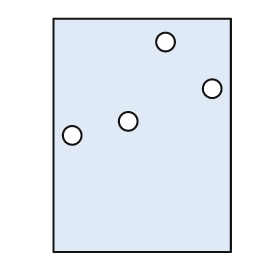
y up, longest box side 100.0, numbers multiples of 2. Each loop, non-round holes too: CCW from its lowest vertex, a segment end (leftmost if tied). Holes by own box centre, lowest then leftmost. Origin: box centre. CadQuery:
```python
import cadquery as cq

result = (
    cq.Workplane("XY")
    .moveTo(-38.0, -50.0)
    .lineTo(38.0, -50.0)
    .lineTo(38.0, 50.0)
    .lineTo(-38.0, 50.0)
    .close()
    .moveTo(-30.0, 0.0)
    .circle(4.0)
    .moveTo(-6.0, 6.0)
    .circle(4.0)
    .moveTo(30.0, 20.0)
    .circle(4.0)
    .moveTo(10.0, 40.0)
    .circle(4.0)
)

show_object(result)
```